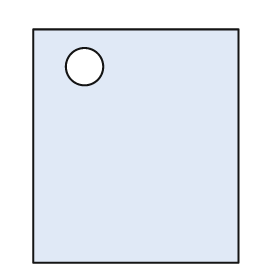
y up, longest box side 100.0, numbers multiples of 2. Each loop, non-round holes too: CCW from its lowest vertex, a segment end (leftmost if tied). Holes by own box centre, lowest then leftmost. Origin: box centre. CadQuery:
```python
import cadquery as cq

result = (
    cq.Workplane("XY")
    .moveTo(-44.0, -50.0)
    .lineTo(44.0, -50.0)
    .lineTo(44.0, 50.0)
    .lineTo(-44.0, 50.0)
    .close()
    .moveTo(-22.0, 34.0)
    .circle(8.0)
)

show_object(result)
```